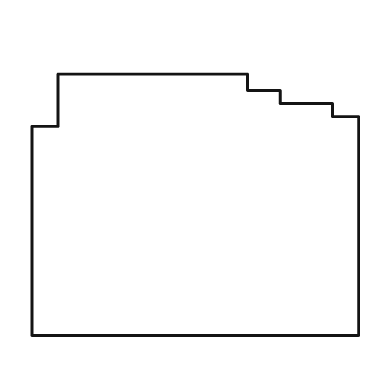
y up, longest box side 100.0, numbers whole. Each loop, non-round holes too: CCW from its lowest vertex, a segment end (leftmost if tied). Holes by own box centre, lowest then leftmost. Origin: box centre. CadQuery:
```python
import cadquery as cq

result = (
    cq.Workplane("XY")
    .moveTo(-50.0, -40.0)
    .lineTo(50.0, -40.0)
    .lineTo(50.0, 27.0)
    .lineTo(42.0, 27.0)
    .lineTo(42.0, 31.0)
    .lineTo(26.0, 31.0)
    .lineTo(26.0, 35.0)
    .lineTo(16.0, 35.0)
    .lineTo(16.0, 40.0)
    .lineTo(-42.0, 40.0)
    .lineTo(-42.0, 24.0)
    .lineTo(-50.0, 24.0)
    .close()
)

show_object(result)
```